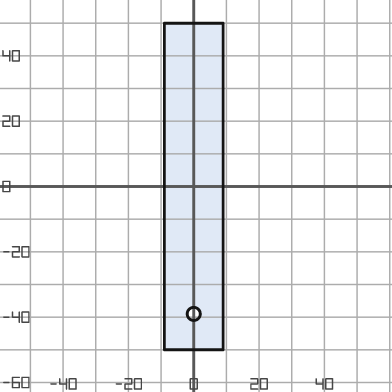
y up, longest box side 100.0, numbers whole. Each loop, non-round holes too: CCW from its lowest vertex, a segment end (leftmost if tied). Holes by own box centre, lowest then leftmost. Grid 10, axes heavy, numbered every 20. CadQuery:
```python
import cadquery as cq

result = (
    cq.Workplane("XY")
    .moveTo(-9.0, -50.0)
    .lineTo(9.0, -50.0)
    .lineTo(9.0, 50.0)
    .lineTo(-9.0, 50.0)
    .close()
    .moveTo(0.0, -39.0)
    .circle(2.0)
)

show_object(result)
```